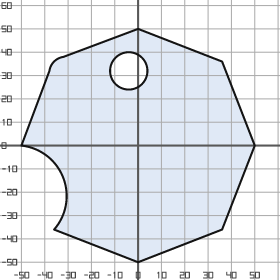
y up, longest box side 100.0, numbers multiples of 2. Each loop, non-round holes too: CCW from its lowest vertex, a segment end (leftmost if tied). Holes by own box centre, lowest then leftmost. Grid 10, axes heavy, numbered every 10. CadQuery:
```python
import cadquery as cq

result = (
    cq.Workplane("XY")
    .moveTo(0.0, -50.0)
    .lineTo(36.0, -36.0)
    .lineTo(50.0, 0.0)
    .lineTo(36.0, 36.0)
    .lineTo(0.0, 50.0)
    .lineTo(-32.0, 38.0)
    .threePointArc((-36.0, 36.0), (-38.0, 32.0))
    .lineTo(-50.0, 0.0)
    .threePointArc((-32.0, -14.0), (-36.0, -36.0))
    .close()
    .moveTo(-4.0, 32.0)
    .circle(8.0)
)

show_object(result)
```